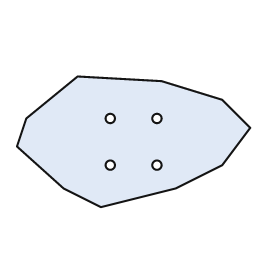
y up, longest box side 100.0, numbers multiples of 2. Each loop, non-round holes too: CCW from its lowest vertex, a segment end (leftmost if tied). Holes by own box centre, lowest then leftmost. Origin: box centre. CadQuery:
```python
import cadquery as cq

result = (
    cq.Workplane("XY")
    .moveTo(-14.0, -28.0)
    .lineTo(18.0, -20.0)
    .lineTo(38.0, -10.0)
    .lineTo(50.0, 6.0)
    .lineTo(38.0, 18.0)
    .lineTo(12.0, 26.0)
    .lineTo(-24.0, 28.0)
    .lineTo(-46.0, 10.0)
    .lineTo(-50.0, -2.0)
    .lineTo(-30.0, -20.0)
    .close()
    .moveTo(-10.0, -10.0)
    .circle(2.0)
    .moveTo(10.0, -10.0)
    .circle(2.0)
    .moveTo(-10.0, 10.0)
    .circle(2.0)
    .moveTo(10.0, 10.0)
    .circle(2.0)
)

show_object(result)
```